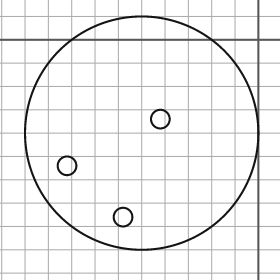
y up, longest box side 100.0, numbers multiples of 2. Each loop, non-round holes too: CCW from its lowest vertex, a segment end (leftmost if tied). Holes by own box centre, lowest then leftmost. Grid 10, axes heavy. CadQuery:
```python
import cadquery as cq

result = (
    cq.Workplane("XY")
    .moveTo(-50.0, -40.0)
    .circle(50.0)
    .moveTo(-58.0, -76.0)
    .circle(4.0)
    .moveTo(-82.0, -54.0)
    .circle(4.0)
    .moveTo(-42.0, -34.0)
    .circle(4.0)
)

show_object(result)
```